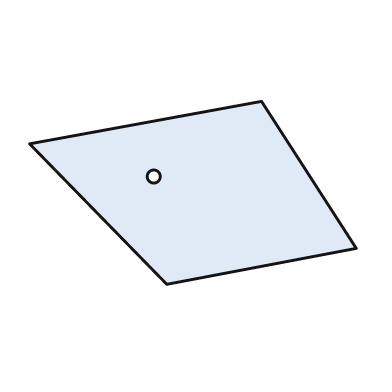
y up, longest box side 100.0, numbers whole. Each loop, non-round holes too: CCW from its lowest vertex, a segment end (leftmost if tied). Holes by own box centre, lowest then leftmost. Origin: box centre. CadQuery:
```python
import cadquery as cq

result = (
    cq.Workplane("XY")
    .moveTo(-8.0, -28.0)
    .lineTo(50.0, -17.0)
    .lineTo(21.0, 28.0)
    .lineTo(-50.0, 15.0)
    .close()
    .moveTo(-12.0, 5.0)
    .circle(2.0)
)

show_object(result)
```